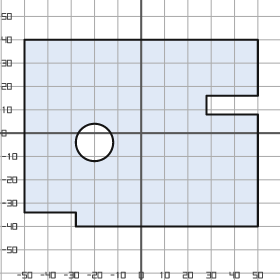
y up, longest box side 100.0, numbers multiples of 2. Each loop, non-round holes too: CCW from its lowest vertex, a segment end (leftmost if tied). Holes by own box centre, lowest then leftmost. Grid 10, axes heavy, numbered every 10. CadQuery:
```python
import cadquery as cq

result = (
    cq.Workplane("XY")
    .moveTo(-28.0, -40.0)
    .lineTo(50.0, -40.0)
    .lineTo(50.0, 8.0)
    .lineTo(28.0, 8.0)
    .lineTo(28.0, 16.0)
    .lineTo(50.0, 16.0)
    .lineTo(50.0, 40.0)
    .lineTo(-50.0, 40.0)
    .lineTo(-50.0, -34.0)
    .lineTo(-28.0, -34.0)
    .close()
    .moveTo(-20.0, -4.0)
    .circle(8.0)
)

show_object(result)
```